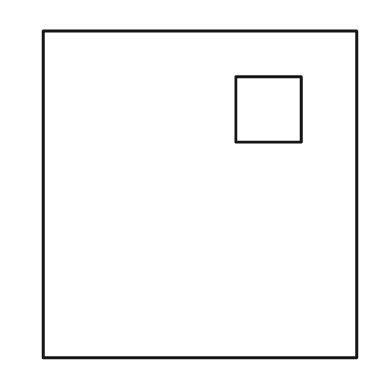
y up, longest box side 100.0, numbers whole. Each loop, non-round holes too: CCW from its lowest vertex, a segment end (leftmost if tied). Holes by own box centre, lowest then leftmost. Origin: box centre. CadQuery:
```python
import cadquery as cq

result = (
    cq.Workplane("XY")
    .moveTo(-48.0, -50.0)
    .lineTo(48.0, -50.0)
    .lineTo(48.0, 50.0)
    .lineTo(-48.0, 50.0)
    .close()
    .moveTo(11.0, 16.0)
    .lineTo(31.0, 16.0)
    .lineTo(31.0, 36.0)
    .lineTo(11.0, 36.0)
    .close()
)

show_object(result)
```